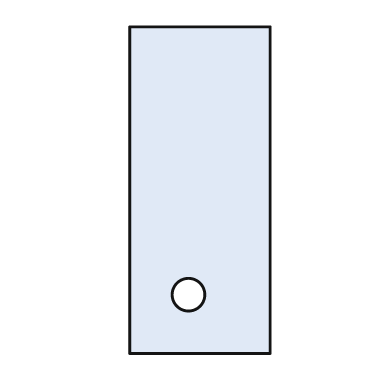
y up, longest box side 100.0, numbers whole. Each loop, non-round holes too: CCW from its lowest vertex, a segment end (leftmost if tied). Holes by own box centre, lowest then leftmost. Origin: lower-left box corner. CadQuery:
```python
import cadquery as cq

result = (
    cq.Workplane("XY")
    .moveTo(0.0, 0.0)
    .lineTo(43.0, 0.0)
    .lineTo(43.0, 100.0)
    .lineTo(0.0, 100.0)
    .close()
    .moveTo(18.0, 18.0)
    .circle(5.0)
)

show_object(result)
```